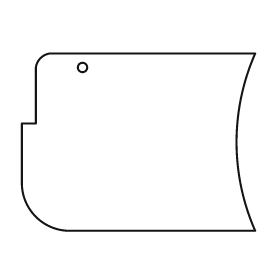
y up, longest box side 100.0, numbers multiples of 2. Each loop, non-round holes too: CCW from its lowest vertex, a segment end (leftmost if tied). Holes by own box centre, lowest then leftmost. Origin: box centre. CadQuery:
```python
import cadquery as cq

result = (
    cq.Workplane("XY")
    .moveTo(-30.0, -38.0)
    .lineTo(50.0, -38.0)
    .threePointArc((42.0, 0.0), (50.0, 38.0))
    .lineTo(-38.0, 38.0)
    .threePointArc((-42.0, 36.0), (-44.0, 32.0))
    .lineTo(-44.0, 8.0)
    .lineTo(-50.0, 8.0)
    .lineTo(-50.0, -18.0)
    .threePointArc((-44.0, -32.0), (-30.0, -38.0))
    .close()
    .moveTo(-24.0, 32.0)
    .circle(2.0)
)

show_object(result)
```